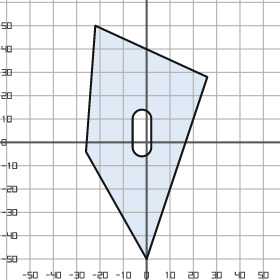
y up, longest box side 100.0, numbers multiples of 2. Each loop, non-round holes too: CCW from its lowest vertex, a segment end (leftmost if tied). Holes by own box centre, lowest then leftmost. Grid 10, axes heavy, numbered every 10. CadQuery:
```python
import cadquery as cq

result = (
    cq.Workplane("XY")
    .moveTo(0.0, -50.0)
    .lineTo(26.0, 28.0)
    .lineTo(-22.0, 50.0)
    .lineTo(-26.0, -4.0)
    .close()
    .moveTo(-6.0, -2.0)
    .threePointArc((-2.0, -6.0), (2.0, -2.0))
    .lineTo(2.0, 10.0)
    .threePointArc((-2.0, 14.0), (-6.0, 10.0))
    .close()
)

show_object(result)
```